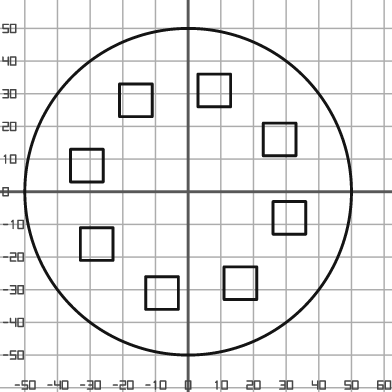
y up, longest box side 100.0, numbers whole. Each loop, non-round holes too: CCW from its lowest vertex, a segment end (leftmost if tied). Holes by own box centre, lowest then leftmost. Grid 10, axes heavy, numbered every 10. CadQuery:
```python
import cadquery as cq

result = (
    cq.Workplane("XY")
    .moveTo(0.0, 0.0)
    .circle(50.0)
    .moveTo(-13.0, -36.0)
    .lineTo(-3.0, -36.0)
    .lineTo(-3.0, -26.0)
    .lineTo(-13.0, -26.0)
    .close()
    .moveTo(11.0, -33.0)
    .lineTo(21.0, -33.0)
    .lineTo(21.0, -23.0)
    .lineTo(11.0, -23.0)
    .close()
    .moveTo(-33.0, -21.0)
    .lineTo(-23.0, -21.0)
    .lineTo(-23.0, -11.0)
    .lineTo(-33.0, -11.0)
    .close()
    .moveTo(26.0, -13.0)
    .lineTo(36.0, -13.0)
    .lineTo(36.0, -3.0)
    .lineTo(26.0, -3.0)
    .close()
    .moveTo(-36.0, 3.0)
    .lineTo(-26.0, 3.0)
    .lineTo(-26.0, 13.0)
    .lineTo(-36.0, 13.0)
    .close()
    .moveTo(23.0, 11.0)
    .lineTo(33.0, 11.0)
    .lineTo(33.0, 21.0)
    .lineTo(23.0, 21.0)
    .close()
    .moveTo(-21.0, 23.0)
    .lineTo(-11.0, 23.0)
    .lineTo(-11.0, 33.0)
    .lineTo(-21.0, 33.0)
    .close()
    .moveTo(3.0, 26.0)
    .lineTo(13.0, 26.0)
    .lineTo(13.0, 36.0)
    .lineTo(3.0, 36.0)
    .close()
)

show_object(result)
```